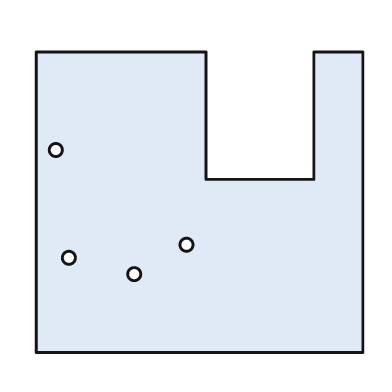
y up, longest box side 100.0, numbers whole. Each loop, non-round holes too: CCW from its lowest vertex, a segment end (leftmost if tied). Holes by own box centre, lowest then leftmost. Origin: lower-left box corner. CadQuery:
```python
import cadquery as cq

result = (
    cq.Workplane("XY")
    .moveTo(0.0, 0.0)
    .lineTo(100.0, 0.0)
    .lineTo(100.0, 92.0)
    .lineTo(85.0, 92.0)
    .lineTo(85.0, 53.0)
    .lineTo(52.0, 53.0)
    .lineTo(52.0, 92.0)
    .lineTo(0.0, 92.0)
    .close()
    .moveTo(30.0, 24.0)
    .circle(2.0)
    .moveTo(10.0, 29.0)
    .circle(2.0)
    .moveTo(46.0, 33.0)
    .circle(2.0)
    .moveTo(6.0, 62.0)
    .circle(2.0)
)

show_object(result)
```